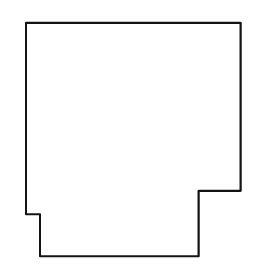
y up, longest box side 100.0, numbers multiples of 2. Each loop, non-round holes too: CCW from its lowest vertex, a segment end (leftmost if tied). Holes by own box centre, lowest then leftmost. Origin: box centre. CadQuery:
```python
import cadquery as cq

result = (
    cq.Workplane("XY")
    .moveTo(-40.0, -50.0)
    .lineTo(28.0, -50.0)
    .lineTo(28.0, -22.0)
    .lineTo(46.0, -22.0)
    .lineTo(46.0, 50.0)
    .lineTo(-46.0, 50.0)
    .lineTo(-46.0, -32.0)
    .lineTo(-40.0, -32.0)
    .close()
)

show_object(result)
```